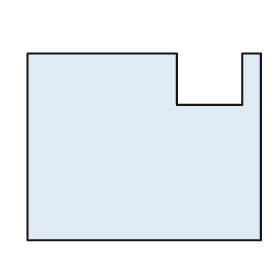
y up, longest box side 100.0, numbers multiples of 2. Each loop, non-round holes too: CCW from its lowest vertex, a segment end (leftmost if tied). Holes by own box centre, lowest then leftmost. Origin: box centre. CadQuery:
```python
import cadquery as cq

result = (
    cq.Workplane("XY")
    .moveTo(-50.0, -40.0)
    .lineTo(50.0, -40.0)
    .lineTo(50.0, 40.0)
    .lineTo(42.0, 40.0)
    .lineTo(42.0, 18.0)
    .lineTo(14.0, 18.0)
    .lineTo(14.0, 40.0)
    .lineTo(-50.0, 40.0)
    .close()
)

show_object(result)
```